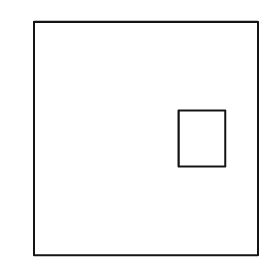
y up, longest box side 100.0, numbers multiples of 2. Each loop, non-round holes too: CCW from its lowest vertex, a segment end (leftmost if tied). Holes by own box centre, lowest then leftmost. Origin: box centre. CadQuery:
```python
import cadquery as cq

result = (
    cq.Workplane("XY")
    .moveTo(-48.0, -50.0)
    .lineTo(48.0, -50.0)
    .lineTo(48.0, 50.0)
    .lineTo(-48.0, 50.0)
    .close()
    .moveTo(14.0, -12.0)
    .lineTo(34.0, -12.0)
    .lineTo(34.0, 12.0)
    .lineTo(14.0, 12.0)
    .close()
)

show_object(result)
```